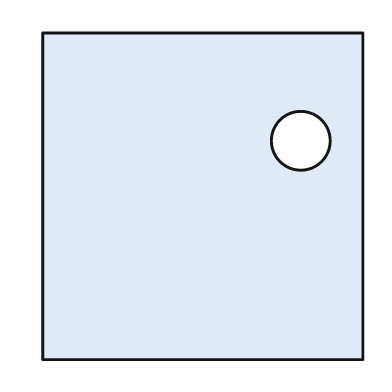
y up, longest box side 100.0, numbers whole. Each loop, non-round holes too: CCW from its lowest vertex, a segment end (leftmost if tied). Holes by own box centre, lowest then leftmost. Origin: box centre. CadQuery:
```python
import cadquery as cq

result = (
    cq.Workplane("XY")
    .moveTo(-49.0, -50.0)
    .lineTo(49.0, -50.0)
    .lineTo(49.0, 50.0)
    .lineTo(-49.0, 50.0)
    .close()
    .moveTo(30.0, 17.0)
    .circle(9.0)
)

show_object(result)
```